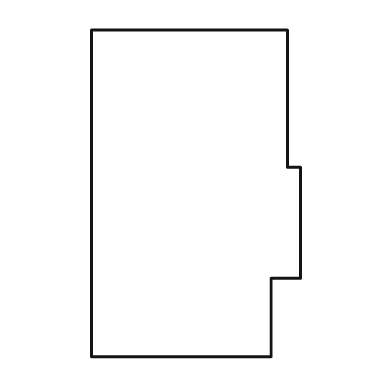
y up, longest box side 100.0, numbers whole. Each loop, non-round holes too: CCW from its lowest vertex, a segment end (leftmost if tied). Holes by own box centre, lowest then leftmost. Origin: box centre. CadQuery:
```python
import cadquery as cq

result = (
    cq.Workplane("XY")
    .moveTo(-32.0, -50.0)
    .lineTo(23.0, -50.0)
    .lineTo(23.0, -26.0)
    .lineTo(32.0, -26.0)
    .lineTo(32.0, 8.0)
    .lineTo(28.0, 8.0)
    .lineTo(28.0, 50.0)
    .lineTo(-32.0, 50.0)
    .close()
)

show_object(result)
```